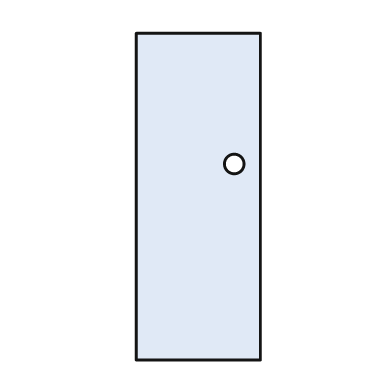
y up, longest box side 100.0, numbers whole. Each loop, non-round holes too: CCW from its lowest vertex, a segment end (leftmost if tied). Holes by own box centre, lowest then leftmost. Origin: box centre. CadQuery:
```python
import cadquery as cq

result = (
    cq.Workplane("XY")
    .moveTo(-19.0, -50.0)
    .lineTo(19.0, -50.0)
    .lineTo(19.0, 50.0)
    .lineTo(-19.0, 50.0)
    .close()
    .moveTo(11.0, 10.0)
    .circle(3.0)
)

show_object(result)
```